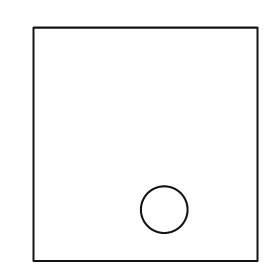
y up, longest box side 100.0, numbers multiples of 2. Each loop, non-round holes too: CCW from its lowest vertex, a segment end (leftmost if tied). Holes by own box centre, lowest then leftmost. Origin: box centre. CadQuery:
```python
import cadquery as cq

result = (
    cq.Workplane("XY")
    .moveTo(-48.0, -50.0)
    .lineTo(48.0, -50.0)
    .lineTo(48.0, 50.0)
    .lineTo(-48.0, 50.0)
    .close()
    .moveTo(8.0, -28.0)
    .circle(10.0)
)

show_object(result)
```